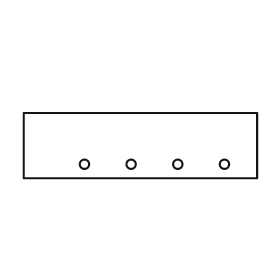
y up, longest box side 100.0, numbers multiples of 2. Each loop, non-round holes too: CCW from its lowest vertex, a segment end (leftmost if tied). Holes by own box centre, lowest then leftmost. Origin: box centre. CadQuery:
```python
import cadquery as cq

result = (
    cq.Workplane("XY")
    .moveTo(-50.0, -14.0)
    .lineTo(50.0, -14.0)
    .lineTo(50.0, 14.0)
    .lineTo(-50.0, 14.0)
    .close()
    .moveTo(-24.0, -8.0)
    .circle(2.0)
    .moveTo(-4.0, -8.0)
    .circle(2.0)
    .moveTo(16.0, -8.0)
    .circle(2.0)
    .moveTo(36.0, -8.0)
    .circle(2.0)
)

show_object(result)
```